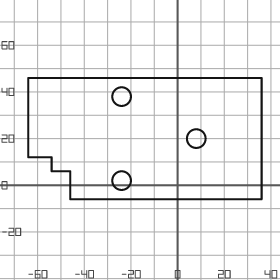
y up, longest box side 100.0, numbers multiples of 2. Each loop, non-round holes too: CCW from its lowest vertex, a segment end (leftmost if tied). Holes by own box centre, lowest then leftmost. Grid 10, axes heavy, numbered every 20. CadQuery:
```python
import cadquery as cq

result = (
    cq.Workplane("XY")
    .moveTo(-46.0, -6.0)
    .lineTo(36.0, -6.0)
    .lineTo(36.0, 46.0)
    .lineTo(-64.0, 46.0)
    .lineTo(-64.0, 12.0)
    .lineTo(-54.0, 12.0)
    .lineTo(-54.0, 6.0)
    .lineTo(-46.0, 6.0)
    .close()
    .moveTo(-24.0, 2.0)
    .circle(4.0)
    .moveTo(8.0, 20.0)
    .circle(4.0)
    .moveTo(-24.0, 38.0)
    .circle(4.0)
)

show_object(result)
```